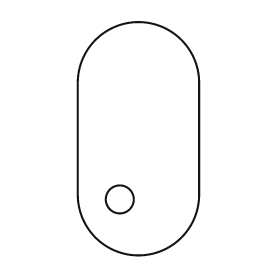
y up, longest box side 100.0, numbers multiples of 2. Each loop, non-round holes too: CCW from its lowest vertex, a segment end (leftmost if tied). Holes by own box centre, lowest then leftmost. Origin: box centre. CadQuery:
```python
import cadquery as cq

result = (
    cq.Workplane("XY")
    .moveTo(-26.0, -24.0)
    .threePointArc((0.0, -50.0), (26.0, -24.0))
    .lineTo(26.0, 24.0)
    .threePointArc((0.0, 50.0), (-26.0, 24.0))
    .close()
    .moveTo(-8.0, -26.0)
    .circle(6.0)
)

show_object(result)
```